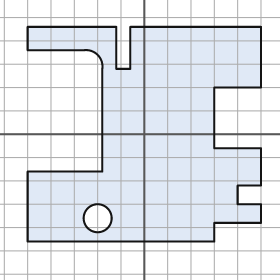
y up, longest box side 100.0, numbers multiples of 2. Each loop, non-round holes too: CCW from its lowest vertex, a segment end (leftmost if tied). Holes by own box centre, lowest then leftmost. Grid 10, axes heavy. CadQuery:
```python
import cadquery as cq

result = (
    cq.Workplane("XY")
    .moveTo(-50.0, -46.0)
    .lineTo(30.0, -46.0)
    .lineTo(30.0, -38.0)
    .lineTo(50.0, -38.0)
    .lineTo(50.0, -30.0)
    .lineTo(40.0, -30.0)
    .lineTo(40.0, -22.0)
    .lineTo(50.0, -22.0)
    .lineTo(50.0, -6.0)
    .lineTo(30.0, -6.0)
    .lineTo(30.0, 20.0)
    .lineTo(50.0, 20.0)
    .lineTo(50.0, 46.0)
    .lineTo(-6.0, 46.0)
    .lineTo(-6.0, 28.0)
    .lineTo(-12.0, 28.0)
    .lineTo(-12.0, 46.0)
    .lineTo(-50.0, 46.0)
    .lineTo(-50.0, 36.0)
    .lineTo(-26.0, 36.0)
    .threePointArc((-20.0, 34.0), (-18.0, 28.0))
    .lineTo(-18.0, -16.0)
    .lineTo(-50.0, -16.0)
    .close()
    .moveTo(-20.0, -36.0)
    .circle(6.0)
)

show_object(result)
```